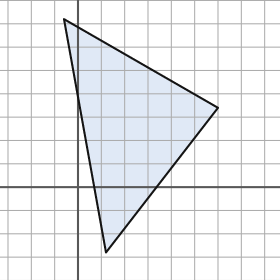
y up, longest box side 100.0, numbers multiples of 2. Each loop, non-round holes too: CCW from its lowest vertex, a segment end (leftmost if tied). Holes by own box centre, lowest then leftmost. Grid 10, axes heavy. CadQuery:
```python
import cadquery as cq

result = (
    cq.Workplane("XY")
    .moveTo(12.0, -28.0)
    .lineTo(60.0, 34.0)
    .lineTo(-6.0, 72.0)
    .close()
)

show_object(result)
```